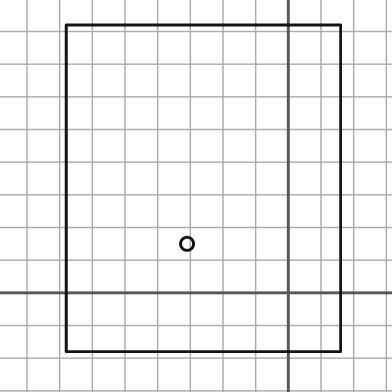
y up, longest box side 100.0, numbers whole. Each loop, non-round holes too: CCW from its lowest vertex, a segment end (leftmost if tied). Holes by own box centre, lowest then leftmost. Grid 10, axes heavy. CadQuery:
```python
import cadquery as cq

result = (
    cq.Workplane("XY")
    .moveTo(-68.0, -18.0)
    .lineTo(16.0, -18.0)
    .lineTo(16.0, 82.0)
    .lineTo(-68.0, 82.0)
    .close()
    .moveTo(-31.0, 15.0)
    .circle(2.0)
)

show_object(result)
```